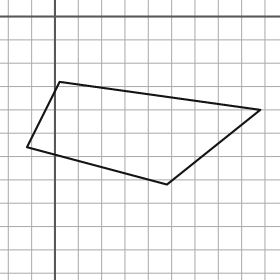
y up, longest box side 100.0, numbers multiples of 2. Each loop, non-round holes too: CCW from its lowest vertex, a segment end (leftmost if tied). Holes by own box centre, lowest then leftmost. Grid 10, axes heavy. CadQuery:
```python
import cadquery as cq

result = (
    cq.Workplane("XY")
    .moveTo(48.0, -72.0)
    .lineTo(88.0, -40.0)
    .lineTo(2.0, -28.0)
    .lineTo(-12.0, -56.0)
    .close()
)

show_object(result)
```